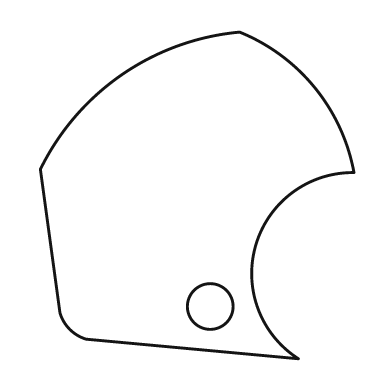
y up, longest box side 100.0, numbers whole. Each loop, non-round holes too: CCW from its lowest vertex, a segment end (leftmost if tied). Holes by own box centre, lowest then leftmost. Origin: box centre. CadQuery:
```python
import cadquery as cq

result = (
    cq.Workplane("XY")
    .moveTo(31.0, -50.0)
    .threePointArc((18.0, -15.0), (48.0, 7.0))
    .threePointArc((36.0, 33.0), (13.0, 50.0))
    .threePointArc((-23.0, 37.0), (-48.0, 8.0))
    .lineTo(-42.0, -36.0)
    .threePointArc((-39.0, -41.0), (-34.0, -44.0))
    .close()
    .moveTo(4.0, -34.0)
    .circle(7.0)
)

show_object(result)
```